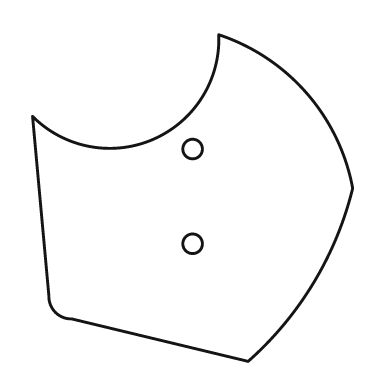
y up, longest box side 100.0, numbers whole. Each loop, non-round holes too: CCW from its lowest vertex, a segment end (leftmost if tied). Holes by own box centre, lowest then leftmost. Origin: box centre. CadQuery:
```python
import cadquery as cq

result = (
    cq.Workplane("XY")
    .moveTo(17.0, -50.0)
    .threePointArc((37.0, -26.0), (49.0, 3.0))
    .threePointArc((35.0, 32.0), (8.0, 50.0))
    .threePointArc((-12.0, 18.0), (-49.0, 25.0))
    .lineTo(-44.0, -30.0)
    .threePointArc((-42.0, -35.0), (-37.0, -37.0))
    .close()
    .moveTo(0.0, -14.0)
    .circle(3.0)
    .moveTo(0.0, 15.0)
    .circle(3.0)
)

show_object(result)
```